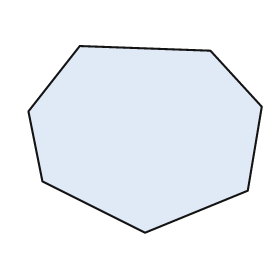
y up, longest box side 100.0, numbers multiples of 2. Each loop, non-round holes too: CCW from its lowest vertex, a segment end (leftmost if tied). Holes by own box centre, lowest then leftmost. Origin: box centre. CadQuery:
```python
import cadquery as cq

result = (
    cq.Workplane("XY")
    .moveTo(0.0, -40.0)
    .lineTo(44.0, -22.0)
    .lineTo(50.0, 14.0)
    .lineTo(28.0, 38.0)
    .lineTo(-28.0, 40.0)
    .lineTo(-50.0, 12.0)
    .lineTo(-44.0, -18.0)
    .close()
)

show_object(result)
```